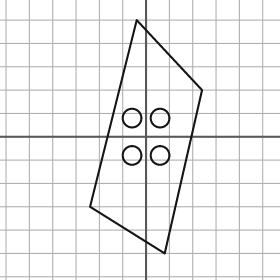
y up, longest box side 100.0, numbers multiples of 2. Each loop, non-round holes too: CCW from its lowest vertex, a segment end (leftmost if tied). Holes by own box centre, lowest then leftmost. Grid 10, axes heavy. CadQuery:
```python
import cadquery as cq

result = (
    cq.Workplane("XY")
    .moveTo(8.0, -50.0)
    .lineTo(24.0, 20.0)
    .lineTo(-4.0, 50.0)
    .lineTo(-24.0, -30.0)
    .close()
    .moveTo(-6.0, -8.0)
    .circle(4.0)
    .moveTo(6.0, -8.0)
    .circle(4.0)
    .moveTo(-6.0, 8.0)
    .circle(4.0)
    .moveTo(6.0, 8.0)
    .circle(4.0)
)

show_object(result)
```